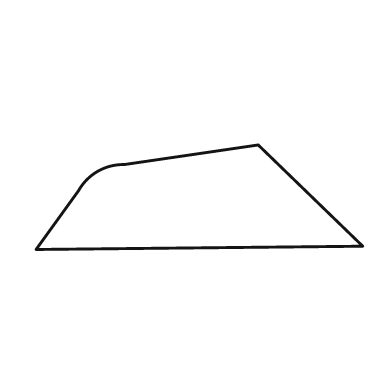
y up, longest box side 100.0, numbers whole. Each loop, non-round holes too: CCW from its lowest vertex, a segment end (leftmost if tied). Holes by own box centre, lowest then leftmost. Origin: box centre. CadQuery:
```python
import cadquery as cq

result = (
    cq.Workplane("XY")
    .moveTo(-50.0, -16.0)
    .lineTo(50.0, -15.0)
    .lineTo(18.0, 16.0)
    .lineTo(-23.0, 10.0)
    .threePointArc((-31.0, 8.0), (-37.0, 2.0))
    .close()
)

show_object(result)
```